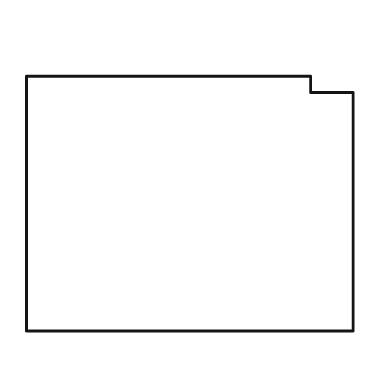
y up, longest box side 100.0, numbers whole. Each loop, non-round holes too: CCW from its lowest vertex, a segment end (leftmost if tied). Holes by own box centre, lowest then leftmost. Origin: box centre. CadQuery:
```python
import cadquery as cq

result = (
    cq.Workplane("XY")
    .moveTo(-50.0, -39.0)
    .lineTo(50.0, -39.0)
    .lineTo(50.0, 34.0)
    .lineTo(37.0, 34.0)
    .lineTo(37.0, 39.0)
    .lineTo(-50.0, 39.0)
    .close()
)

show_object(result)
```